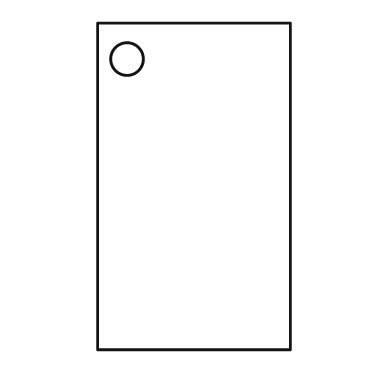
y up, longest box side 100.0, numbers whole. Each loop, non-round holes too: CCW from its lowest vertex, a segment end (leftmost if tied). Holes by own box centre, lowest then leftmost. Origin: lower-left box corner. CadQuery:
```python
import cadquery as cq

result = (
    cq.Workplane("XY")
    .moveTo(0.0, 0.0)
    .lineTo(59.0, 0.0)
    .lineTo(59.0, 100.0)
    .lineTo(0.0, 100.0)
    .close()
    .moveTo(9.0, 89.0)
    .circle(5.0)
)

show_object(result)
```